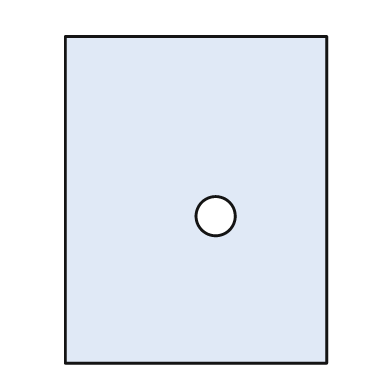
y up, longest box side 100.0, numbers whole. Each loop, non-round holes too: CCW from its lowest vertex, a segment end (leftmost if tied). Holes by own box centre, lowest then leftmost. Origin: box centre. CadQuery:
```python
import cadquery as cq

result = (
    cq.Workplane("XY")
    .moveTo(-40.0, -50.0)
    .lineTo(40.0, -50.0)
    .lineTo(40.0, 50.0)
    .lineTo(-40.0, 50.0)
    .close()
    .moveTo(6.0, -5.0)
    .circle(6.0)
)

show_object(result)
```